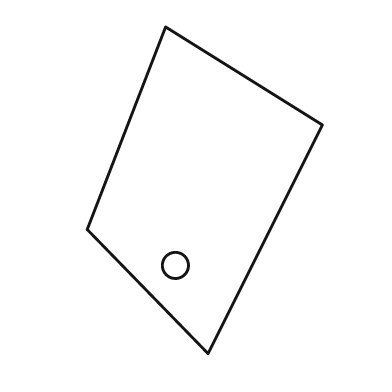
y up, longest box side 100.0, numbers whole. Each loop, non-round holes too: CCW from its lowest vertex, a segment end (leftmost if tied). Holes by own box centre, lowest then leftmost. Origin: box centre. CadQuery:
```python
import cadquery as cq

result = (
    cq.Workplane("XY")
    .moveTo(1.0, -50.0)
    .lineTo(36.0, 20.0)
    .lineTo(-12.0, 50.0)
    .lineTo(-36.0, -12.0)
    .close()
    .moveTo(-9.0, -23.0)
    .circle(4.0)
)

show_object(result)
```